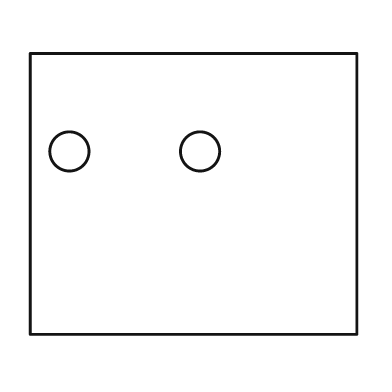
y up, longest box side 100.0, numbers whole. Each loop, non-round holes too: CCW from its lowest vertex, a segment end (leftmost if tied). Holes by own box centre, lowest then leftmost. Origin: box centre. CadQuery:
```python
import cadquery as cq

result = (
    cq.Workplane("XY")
    .moveTo(-50.0, -43.0)
    .lineTo(50.0, -43.0)
    .lineTo(50.0, 43.0)
    .lineTo(-50.0, 43.0)
    .close()
    .moveTo(-38.0, 13.0)
    .circle(6.0)
    .moveTo(2.0, 13.0)
    .circle(6.0)
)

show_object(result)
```